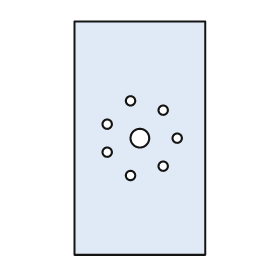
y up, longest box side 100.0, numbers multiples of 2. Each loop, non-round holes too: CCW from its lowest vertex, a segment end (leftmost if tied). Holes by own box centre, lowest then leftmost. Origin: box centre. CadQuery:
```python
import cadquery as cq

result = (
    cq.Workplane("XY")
    .moveTo(-28.0, -50.0)
    .lineTo(28.0, -50.0)
    .lineTo(28.0, 50.0)
    .lineTo(-28.0, 50.0)
    .close()
    .moveTo(-4.0, -16.0)
    .circle(2.0)
    .moveTo(10.0, -12.0)
    .circle(2.0)
    .moveTo(-14.0, -6.0)
    .circle(2.0)
    .moveTo(0.0, 0.0)
    .circle(4.0)
    .moveTo(16.0, 0.0)
    .circle(2.0)
    .moveTo(-14.0, 6.0)
    .circle(2.0)
    .moveTo(10.0, 12.0)
    .circle(2.0)
    .moveTo(-4.0, 16.0)
    .circle(2.0)
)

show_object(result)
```